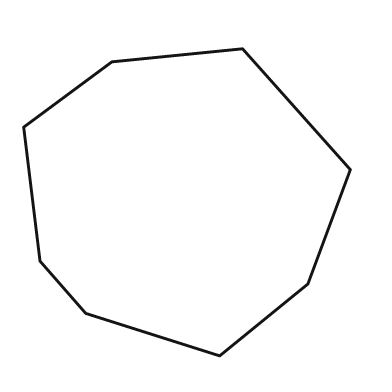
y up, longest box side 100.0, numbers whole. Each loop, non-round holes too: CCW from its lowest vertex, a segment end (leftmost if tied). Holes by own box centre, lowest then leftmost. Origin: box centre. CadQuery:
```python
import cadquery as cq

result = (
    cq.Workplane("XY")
    .moveTo(10.0, -47.0)
    .lineTo(37.0, -25.0)
    .lineTo(50.0, 10.0)
    .lineTo(17.0, 47.0)
    .lineTo(-23.0, 43.0)
    .lineTo(-50.0, 23.0)
    .lineTo(-45.0, -18.0)
    .lineTo(-31.0, -34.0)
    .close()
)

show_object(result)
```